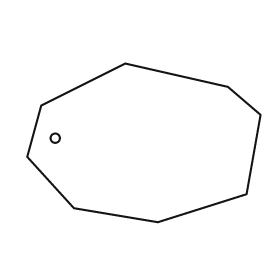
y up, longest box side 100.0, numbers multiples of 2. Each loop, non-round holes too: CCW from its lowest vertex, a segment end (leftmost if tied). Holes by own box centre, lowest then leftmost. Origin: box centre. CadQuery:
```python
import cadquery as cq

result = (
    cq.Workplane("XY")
    .moveTo(6.0, -34.0)
    .lineTo(44.0, -22.0)
    .lineTo(50.0, 12.0)
    .lineTo(36.0, 24.0)
    .lineTo(-8.0, 34.0)
    .lineTo(-44.0, 16.0)
    .lineTo(-50.0, -6.0)
    .lineTo(-30.0, -28.0)
    .close()
    .moveTo(-38.0, 2.0)
    .circle(2.0)
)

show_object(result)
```